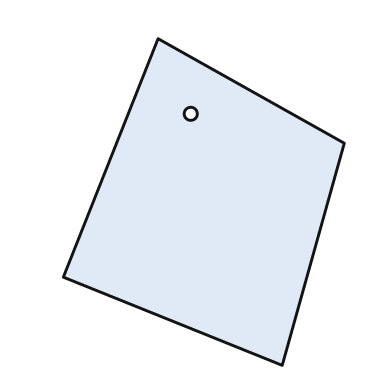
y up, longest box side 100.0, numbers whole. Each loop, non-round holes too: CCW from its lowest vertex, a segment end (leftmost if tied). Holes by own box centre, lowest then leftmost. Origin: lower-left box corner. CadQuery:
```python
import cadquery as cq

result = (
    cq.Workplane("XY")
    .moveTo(67.0, 0.0)
    .lineTo(86.0, 68.0)
    .lineTo(29.0, 100.0)
    .lineTo(0.0, 27.0)
    .close()
    .moveTo(39.0, 77.0)
    .circle(2.0)
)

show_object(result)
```